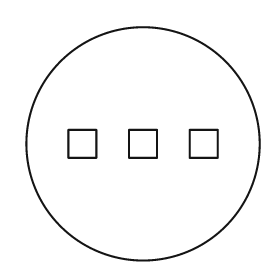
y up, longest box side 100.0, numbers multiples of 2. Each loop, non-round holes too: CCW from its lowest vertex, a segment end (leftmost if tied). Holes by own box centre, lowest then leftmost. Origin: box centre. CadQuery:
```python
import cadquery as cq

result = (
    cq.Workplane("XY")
    .moveTo(0.0, 0.0)
    .circle(50.0)
    .moveTo(-32.0, -6.0)
    .lineTo(-20.0, -6.0)
    .lineTo(-20.0, 6.0)
    .lineTo(-32.0, 6.0)
    .close()
    .moveTo(-6.0, -6.0)
    .lineTo(6.0, -6.0)
    .lineTo(6.0, 6.0)
    .lineTo(-6.0, 6.0)
    .close()
    .moveTo(20.0, -6.0)
    .lineTo(32.0, -6.0)
    .lineTo(32.0, 6.0)
    .lineTo(20.0, 6.0)
    .close()
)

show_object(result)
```